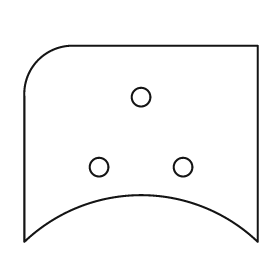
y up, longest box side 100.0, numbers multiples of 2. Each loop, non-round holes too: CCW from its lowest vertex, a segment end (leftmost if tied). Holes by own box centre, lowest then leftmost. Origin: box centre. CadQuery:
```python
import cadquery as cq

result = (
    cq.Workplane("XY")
    .moveTo(-50.0, -42.0)
    .threePointArc((0.0, -22.0), (50.0, -42.0))
    .lineTo(50.0, 42.0)
    .lineTo(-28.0, 42.0)
    .threePointArc((-44.0, 36.0), (-50.0, 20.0))
    .close()
    .moveTo(-18.0, -10.0)
    .circle(4.0)
    .moveTo(18.0, -10.0)
    .circle(4.0)
    .moveTo(0.0, 20.0)
    .circle(4.0)
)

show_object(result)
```